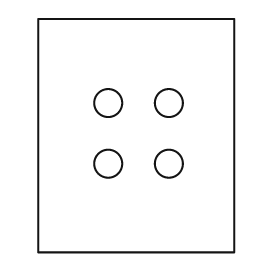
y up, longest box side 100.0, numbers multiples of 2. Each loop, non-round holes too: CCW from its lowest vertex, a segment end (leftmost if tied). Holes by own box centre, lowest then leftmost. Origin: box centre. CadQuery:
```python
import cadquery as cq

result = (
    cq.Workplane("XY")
    .moveTo(-42.0, -50.0)
    .lineTo(42.0, -50.0)
    .lineTo(42.0, 50.0)
    .lineTo(-42.0, 50.0)
    .close()
    .moveTo(-12.0, -12.0)
    .circle(6.0)
    .moveTo(14.0, -12.0)
    .circle(6.0)
    .moveTo(-12.0, 14.0)
    .circle(6.0)
    .moveTo(14.0, 14.0)
    .circle(6.0)
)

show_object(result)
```